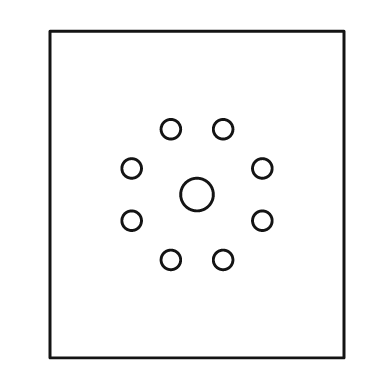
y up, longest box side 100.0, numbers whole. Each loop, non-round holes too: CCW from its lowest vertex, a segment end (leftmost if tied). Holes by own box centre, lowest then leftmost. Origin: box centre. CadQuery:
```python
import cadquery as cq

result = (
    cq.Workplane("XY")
    .moveTo(-45.0, -50.0)
    .lineTo(45.0, -50.0)
    .lineTo(45.0, 50.0)
    .lineTo(-45.0, 50.0)
    .close()
    .moveTo(-8.0, -20.0)
    .circle(3.0)
    .moveTo(8.0, -20.0)
    .circle(3.0)
    .moveTo(-20.0, -8.0)
    .circle(3.0)
    .moveTo(20.0, -8.0)
    .circle(3.0)
    .moveTo(0.0, 0.0)
    .circle(5.0)
    .moveTo(-20.0, 8.0)
    .circle(3.0)
    .moveTo(20.0, 8.0)
    .circle(3.0)
    .moveTo(-8.0, 20.0)
    .circle(3.0)
    .moveTo(8.0, 20.0)
    .circle(3.0)
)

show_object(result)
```